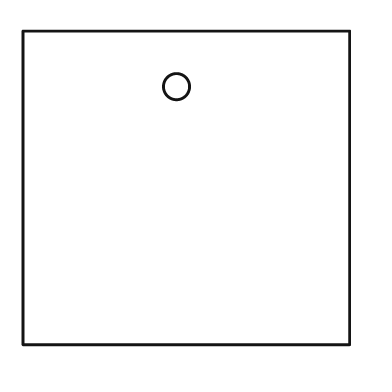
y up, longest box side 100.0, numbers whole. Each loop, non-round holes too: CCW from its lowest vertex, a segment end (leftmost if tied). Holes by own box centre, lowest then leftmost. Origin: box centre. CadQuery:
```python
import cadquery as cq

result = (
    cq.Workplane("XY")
    .moveTo(-50.0, -48.0)
    .lineTo(50.0, -48.0)
    .lineTo(50.0, 48.0)
    .lineTo(-50.0, 48.0)
    .close()
    .moveTo(-3.0, 31.0)
    .circle(4.0)
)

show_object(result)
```